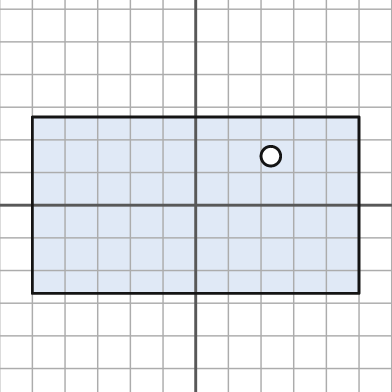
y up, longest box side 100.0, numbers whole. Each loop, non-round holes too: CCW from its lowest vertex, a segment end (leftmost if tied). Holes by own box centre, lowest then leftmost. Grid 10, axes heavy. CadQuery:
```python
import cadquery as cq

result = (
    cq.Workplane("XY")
    .moveTo(-50.0, -27.0)
    .lineTo(50.0, -27.0)
    .lineTo(50.0, 27.0)
    .lineTo(-50.0, 27.0)
    .close()
    .moveTo(23.0, 15.0)
    .circle(3.0)
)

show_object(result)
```